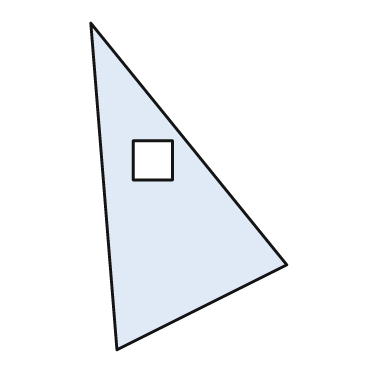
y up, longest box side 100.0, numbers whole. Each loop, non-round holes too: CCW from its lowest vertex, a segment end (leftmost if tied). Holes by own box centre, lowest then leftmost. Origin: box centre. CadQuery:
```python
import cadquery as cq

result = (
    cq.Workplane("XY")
    .moveTo(-22.0, -50.0)
    .lineTo(30.0, -24.0)
    .lineTo(-30.0, 50.0)
    .close()
    .moveTo(-17.0, 2.0)
    .lineTo(-5.0, 2.0)
    .lineTo(-5.0, 14.0)
    .lineTo(-17.0, 14.0)
    .close()
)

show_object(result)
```